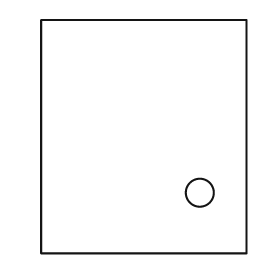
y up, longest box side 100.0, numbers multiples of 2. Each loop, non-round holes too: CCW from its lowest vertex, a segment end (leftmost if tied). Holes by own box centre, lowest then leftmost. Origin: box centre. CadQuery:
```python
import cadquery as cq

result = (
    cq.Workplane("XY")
    .moveTo(-44.0, -50.0)
    .lineTo(44.0, -50.0)
    .lineTo(44.0, 50.0)
    .lineTo(-44.0, 50.0)
    .close()
    .moveTo(24.0, -24.0)
    .circle(6.0)
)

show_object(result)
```